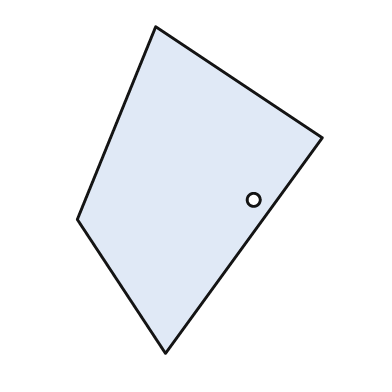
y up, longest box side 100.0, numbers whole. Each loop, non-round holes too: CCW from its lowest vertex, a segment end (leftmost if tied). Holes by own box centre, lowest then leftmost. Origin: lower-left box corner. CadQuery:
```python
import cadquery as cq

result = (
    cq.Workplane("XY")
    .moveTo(27.0, 0.0)
    .lineTo(75.0, 66.0)
    .lineTo(24.0, 100.0)
    .lineTo(0.0, 41.0)
    .close()
    .moveTo(54.0, 47.0)
    .circle(2.0)
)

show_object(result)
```